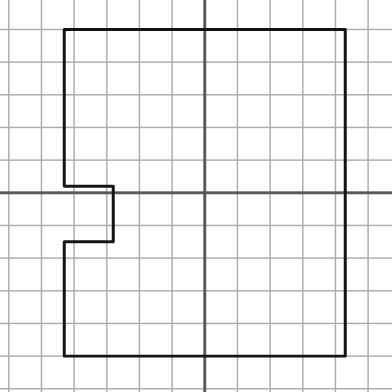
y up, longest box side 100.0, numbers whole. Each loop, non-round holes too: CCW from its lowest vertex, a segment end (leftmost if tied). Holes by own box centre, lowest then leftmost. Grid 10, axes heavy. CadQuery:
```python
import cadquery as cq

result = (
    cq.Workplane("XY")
    .moveTo(-43.0, -50.0)
    .lineTo(43.0, -50.0)
    .lineTo(43.0, 50.0)
    .lineTo(-43.0, 50.0)
    .lineTo(-43.0, 2.0)
    .lineTo(-28.0, 2.0)
    .lineTo(-28.0, -15.0)
    .lineTo(-43.0, -15.0)
    .close()
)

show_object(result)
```